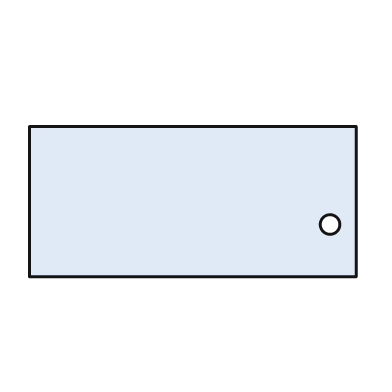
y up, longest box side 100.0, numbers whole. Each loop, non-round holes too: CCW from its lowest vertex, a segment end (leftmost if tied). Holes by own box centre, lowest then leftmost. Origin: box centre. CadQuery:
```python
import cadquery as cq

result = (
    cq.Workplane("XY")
    .moveTo(-50.0, -23.0)
    .lineTo(50.0, -23.0)
    .lineTo(50.0, 23.0)
    .lineTo(-50.0, 23.0)
    .close()
    .moveTo(42.0, -7.0)
    .circle(3.0)
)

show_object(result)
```